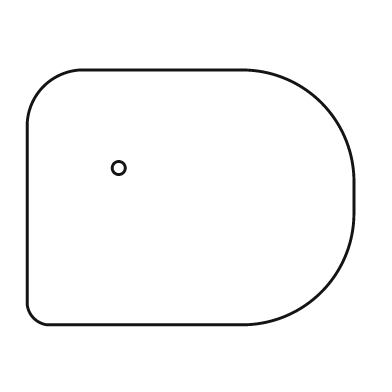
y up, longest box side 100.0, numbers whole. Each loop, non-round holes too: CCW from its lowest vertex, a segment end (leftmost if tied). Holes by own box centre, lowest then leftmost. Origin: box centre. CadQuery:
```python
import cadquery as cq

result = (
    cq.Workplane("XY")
    .moveTo(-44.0, -39.0)
    .lineTo(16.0, -39.0)
    .threePointArc((40.0, -29.0), (50.0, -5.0))
    .lineTo(50.0, 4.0)
    .threePointArc((40.0, 29.0), (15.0, 39.0))
    .lineTo(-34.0, 39.0)
    .threePointArc((-45.0, 34.0), (-50.0, 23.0))
    .lineTo(-50.0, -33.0)
    .threePointArc((-48.0, -37.0), (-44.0, -39.0))
    .close()
    .moveTo(-22.0, 9.0)
    .circle(2.0)
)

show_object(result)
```